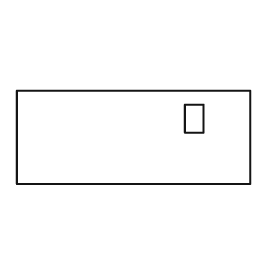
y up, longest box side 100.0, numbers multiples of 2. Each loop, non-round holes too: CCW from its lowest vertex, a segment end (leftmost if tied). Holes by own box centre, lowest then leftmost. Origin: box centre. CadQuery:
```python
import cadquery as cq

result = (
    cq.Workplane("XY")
    .moveTo(-50.0, -20.0)
    .lineTo(50.0, -20.0)
    .lineTo(50.0, 20.0)
    .lineTo(-50.0, 20.0)
    .close()
    .moveTo(22.0, 2.0)
    .lineTo(30.0, 2.0)
    .lineTo(30.0, 14.0)
    .lineTo(22.0, 14.0)
    .close()
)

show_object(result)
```